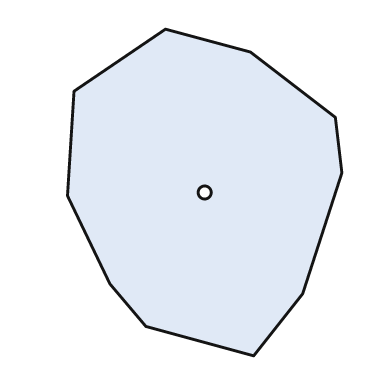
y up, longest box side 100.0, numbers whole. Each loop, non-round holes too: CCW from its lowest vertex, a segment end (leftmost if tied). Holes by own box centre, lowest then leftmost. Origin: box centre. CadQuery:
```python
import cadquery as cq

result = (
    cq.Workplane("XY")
    .moveTo(15.0, -50.0)
    .lineTo(30.0, -31.0)
    .lineTo(42.0, 6.0)
    .lineTo(40.0, 23.0)
    .lineTo(14.0, 43.0)
    .lineTo(-12.0, 50.0)
    .lineTo(-40.0, 31.0)
    .lineTo(-42.0, -1.0)
    .lineTo(-29.0, -28.0)
    .lineTo(-18.0, -41.0)
    .close()
    .moveTo(0.0, 0.0)
    .circle(2.0)
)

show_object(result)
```